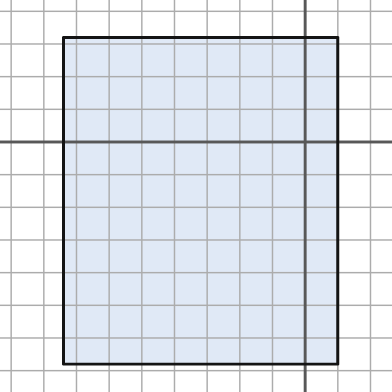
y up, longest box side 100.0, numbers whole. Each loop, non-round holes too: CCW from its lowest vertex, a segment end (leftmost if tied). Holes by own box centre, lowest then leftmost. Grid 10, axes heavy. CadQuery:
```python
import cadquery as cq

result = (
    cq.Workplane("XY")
    .moveTo(-74.0, -68.0)
    .lineTo(10.0, -68.0)
    .lineTo(10.0, 32.0)
    .lineTo(-74.0, 32.0)
    .close()
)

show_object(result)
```